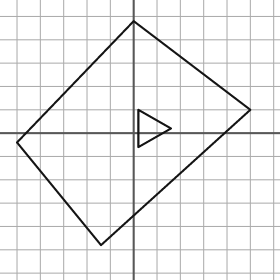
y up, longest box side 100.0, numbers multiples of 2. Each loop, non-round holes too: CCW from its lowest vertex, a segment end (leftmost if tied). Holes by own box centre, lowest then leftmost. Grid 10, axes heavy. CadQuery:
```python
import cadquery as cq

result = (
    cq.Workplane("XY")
    .moveTo(-14.0, -48.0)
    .lineTo(50.0, 10.0)
    .lineTo(0.0, 48.0)
    .lineTo(-50.0, -4.0)
    .close()
    .moveTo(2.0, -6.0)
    .lineTo(16.0, 2.0)
    .lineTo(2.0, 10.0)
    .close()
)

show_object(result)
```